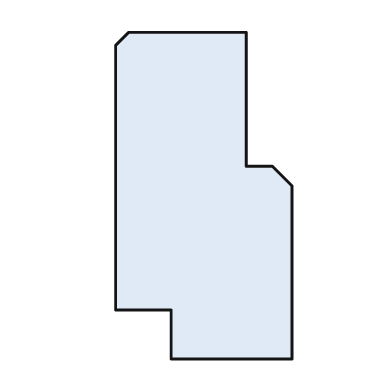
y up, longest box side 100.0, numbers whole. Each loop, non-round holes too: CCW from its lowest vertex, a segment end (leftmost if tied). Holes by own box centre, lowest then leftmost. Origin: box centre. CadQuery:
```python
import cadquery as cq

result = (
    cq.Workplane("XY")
    .moveTo(-10.0, -50.0)
    .lineTo(27.0, -50.0)
    .lineTo(27.0, 3.0)
    .lineTo(21.0, 9.0)
    .lineTo(13.0, 9.0)
    .lineTo(13.0, 50.0)
    .lineTo(-23.0, 50.0)
    .lineTo(-27.0, 46.0)
    .lineTo(-27.0, -35.0)
    .lineTo(-10.0, -35.0)
    .close()
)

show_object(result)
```